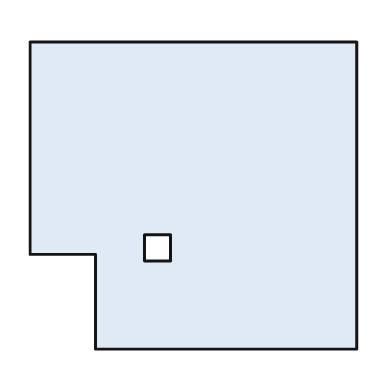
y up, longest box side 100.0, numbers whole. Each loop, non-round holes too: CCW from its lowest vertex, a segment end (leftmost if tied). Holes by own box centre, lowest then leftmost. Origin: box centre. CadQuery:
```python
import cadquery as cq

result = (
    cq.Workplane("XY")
    .moveTo(-30.0, -47.0)
    .lineTo(50.0, -47.0)
    .lineTo(50.0, 47.0)
    .lineTo(-50.0, 47.0)
    .lineTo(-50.0, -18.0)
    .lineTo(-30.0, -18.0)
    .close()
    .moveTo(-15.0, -20.0)
    .lineTo(-7.0, -20.0)
    .lineTo(-7.0, -12.0)
    .lineTo(-15.0, -12.0)
    .close()
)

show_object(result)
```